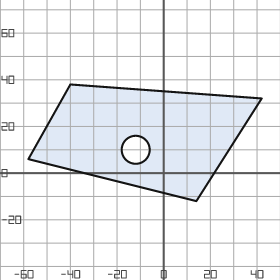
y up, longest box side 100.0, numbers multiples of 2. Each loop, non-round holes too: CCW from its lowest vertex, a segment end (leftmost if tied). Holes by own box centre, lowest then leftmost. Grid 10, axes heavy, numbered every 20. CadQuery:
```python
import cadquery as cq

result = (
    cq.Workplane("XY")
    .moveTo(14.0, -12.0)
    .lineTo(42.0, 32.0)
    .lineTo(-40.0, 38.0)
    .lineTo(-58.0, 6.0)
    .close()
    .moveTo(-12.0, 10.0)
    .circle(6.0)
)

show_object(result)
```